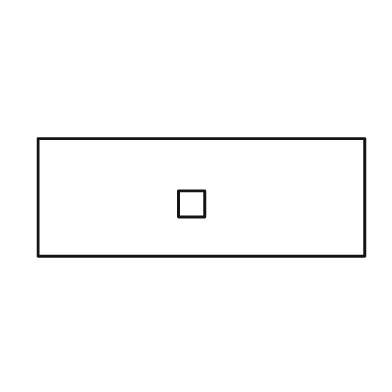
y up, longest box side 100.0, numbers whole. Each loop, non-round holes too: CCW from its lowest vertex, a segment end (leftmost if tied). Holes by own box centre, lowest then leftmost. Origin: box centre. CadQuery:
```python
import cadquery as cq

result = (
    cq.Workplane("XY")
    .moveTo(-50.0, -18.0)
    .lineTo(50.0, -18.0)
    .lineTo(50.0, 18.0)
    .lineTo(-50.0, 18.0)
    .close()
    .moveTo(-7.0, -6.0)
    .lineTo(1.0, -6.0)
    .lineTo(1.0, 2.0)
    .lineTo(-7.0, 2.0)
    .close()
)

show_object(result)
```